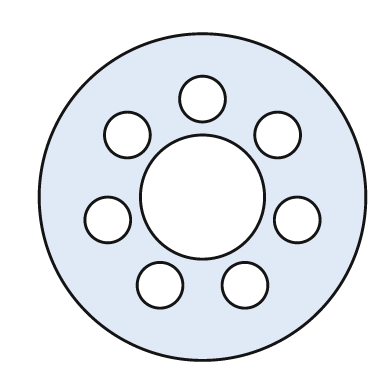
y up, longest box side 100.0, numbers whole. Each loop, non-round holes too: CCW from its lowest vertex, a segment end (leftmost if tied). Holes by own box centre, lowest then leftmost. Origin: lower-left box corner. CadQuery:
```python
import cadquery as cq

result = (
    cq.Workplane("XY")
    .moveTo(50.0, 50.0)
    .circle(50.0)
    .moveTo(37.0, 23.0)
    .circle(7.0)
    .moveTo(63.0, 23.0)
    .circle(7.0)
    .moveTo(21.0, 43.0)
    .circle(7.0)
    .moveTo(79.0, 43.0)
    .circle(7.0)
    .moveTo(50.0, 50.0)
    .circle(19.0)
    .moveTo(27.0, 69.0)
    .circle(7.0)
    .moveTo(73.0, 69.0)
    .circle(7.0)
    .moveTo(50.0, 80.0)
    .circle(7.0)
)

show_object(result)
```